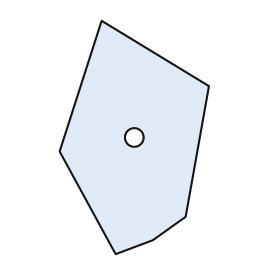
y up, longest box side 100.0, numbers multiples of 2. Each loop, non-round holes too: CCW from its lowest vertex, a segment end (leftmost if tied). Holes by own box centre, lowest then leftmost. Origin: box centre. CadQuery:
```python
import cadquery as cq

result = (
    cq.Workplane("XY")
    .moveTo(-8.0, -50.0)
    .lineTo(8.0, -44.0)
    .lineTo(22.0, -34.0)
    .lineTo(32.0, 22.0)
    .lineTo(-14.0, 50.0)
    .lineTo(-32.0, -6.0)
    .close()
    .moveTo(0.0, 0.0)
    .circle(4.0)
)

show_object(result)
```